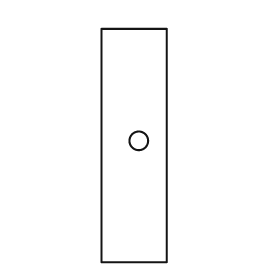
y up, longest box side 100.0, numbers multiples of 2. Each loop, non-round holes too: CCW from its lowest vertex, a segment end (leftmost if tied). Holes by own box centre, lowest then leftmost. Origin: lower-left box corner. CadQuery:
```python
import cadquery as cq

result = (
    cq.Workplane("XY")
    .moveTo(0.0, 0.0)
    .lineTo(28.0, 0.0)
    .lineTo(28.0, 100.0)
    .lineTo(0.0, 100.0)
    .close()
    .moveTo(16.0, 52.0)
    .circle(4.0)
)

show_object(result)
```